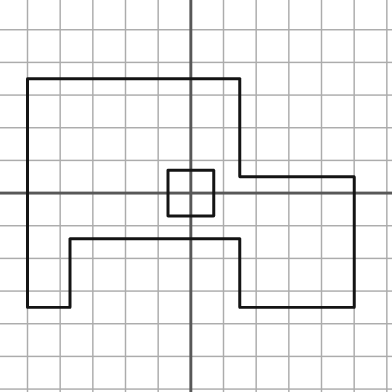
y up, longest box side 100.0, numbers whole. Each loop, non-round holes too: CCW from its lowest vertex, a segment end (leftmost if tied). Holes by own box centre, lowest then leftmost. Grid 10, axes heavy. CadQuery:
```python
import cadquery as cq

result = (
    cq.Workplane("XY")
    .moveTo(-50.0, -35.0)
    .lineTo(-37.0, -35.0)
    .lineTo(-37.0, -14.0)
    .lineTo(15.0, -14.0)
    .lineTo(15.0, -35.0)
    .lineTo(50.0, -35.0)
    .lineTo(50.0, 5.0)
    .lineTo(15.0, 5.0)
    .lineTo(15.0, 35.0)
    .lineTo(-50.0, 35.0)
    .close()
    .moveTo(-7.0, -7.0)
    .lineTo(7.0, -7.0)
    .lineTo(7.0, 7.0)
    .lineTo(-7.0, 7.0)
    .close()
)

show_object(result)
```